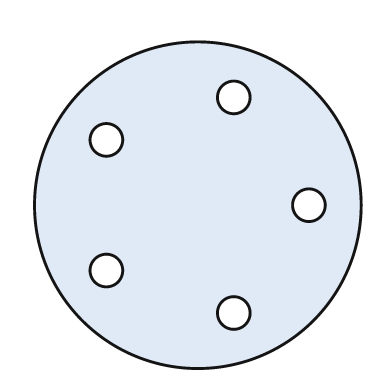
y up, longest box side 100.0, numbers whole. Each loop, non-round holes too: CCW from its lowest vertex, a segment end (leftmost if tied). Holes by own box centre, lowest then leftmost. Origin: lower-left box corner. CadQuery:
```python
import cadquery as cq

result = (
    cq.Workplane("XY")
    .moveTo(50.0, 50.0)
    .circle(50.0)
    .moveTo(61.0, 17.0)
    .circle(5.0)
    .moveTo(22.0, 30.0)
    .circle(5.0)
    .moveTo(84.0, 50.0)
    .circle(5.0)
    .moveTo(22.0, 70.0)
    .circle(5.0)
    .moveTo(61.0, 83.0)
    .circle(5.0)
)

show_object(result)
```